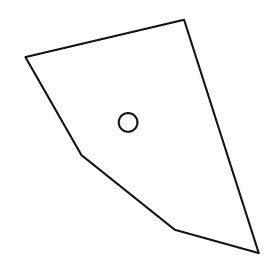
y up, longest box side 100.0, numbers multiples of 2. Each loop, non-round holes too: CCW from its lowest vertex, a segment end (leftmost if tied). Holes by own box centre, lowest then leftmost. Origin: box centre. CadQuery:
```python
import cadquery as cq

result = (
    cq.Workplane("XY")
    .moveTo(50.0, -50.0)
    .lineTo(18.0, 50.0)
    .lineTo(-50.0, 34.0)
    .lineTo(-26.0, -8.0)
    .lineTo(14.0, -40.0)
    .close()
    .moveTo(-6.0, 6.0)
    .circle(4.0)
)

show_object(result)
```